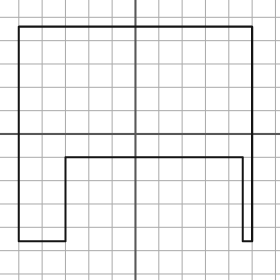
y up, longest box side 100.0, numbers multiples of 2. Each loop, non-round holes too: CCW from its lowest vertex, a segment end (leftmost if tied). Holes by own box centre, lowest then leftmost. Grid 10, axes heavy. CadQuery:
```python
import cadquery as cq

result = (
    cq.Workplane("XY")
    .moveTo(-50.0, -46.0)
    .lineTo(-30.0, -46.0)
    .lineTo(-30.0, -10.0)
    .lineTo(46.0, -10.0)
    .lineTo(46.0, -46.0)
    .lineTo(50.0, -46.0)
    .lineTo(50.0, 46.0)
    .lineTo(-50.0, 46.0)
    .close()
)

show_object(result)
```